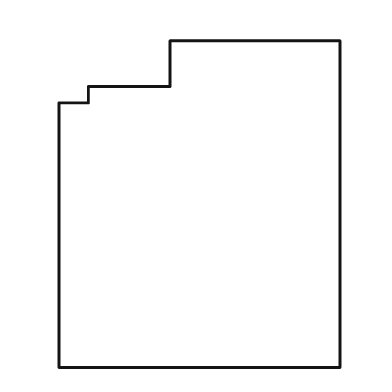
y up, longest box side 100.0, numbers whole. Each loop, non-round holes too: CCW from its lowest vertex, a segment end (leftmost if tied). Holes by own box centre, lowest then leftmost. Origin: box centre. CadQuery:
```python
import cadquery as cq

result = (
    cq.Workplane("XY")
    .moveTo(-43.0, -50.0)
    .lineTo(43.0, -50.0)
    .lineTo(43.0, 50.0)
    .lineTo(-9.0, 50.0)
    .lineTo(-9.0, 36.0)
    .lineTo(-34.0, 36.0)
    .lineTo(-34.0, 31.0)
    .lineTo(-43.0, 31.0)
    .close()
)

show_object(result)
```